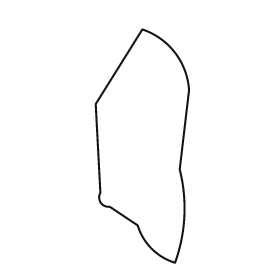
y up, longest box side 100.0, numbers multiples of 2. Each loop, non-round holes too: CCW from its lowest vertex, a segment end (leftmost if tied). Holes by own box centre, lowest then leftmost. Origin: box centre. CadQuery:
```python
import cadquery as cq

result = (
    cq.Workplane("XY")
    .moveTo(14.0, -50.0)
    .threePointArc((18.0, -30.0), (16.0, -10.0))
    .lineTo(20.0, 24.0)
    .threePointArc((14.0, 40.0), (0.0, 50.0))
    .lineTo(-20.0, 18.0)
    .lineTo(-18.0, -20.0)
    .threePointArc((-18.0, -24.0), (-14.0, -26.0))
    .lineTo(-2.0, -34.0)
    .threePointArc((4.0, -44.0), (14.0, -50.0))
    .close()
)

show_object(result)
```